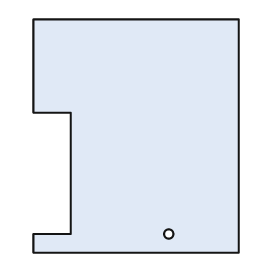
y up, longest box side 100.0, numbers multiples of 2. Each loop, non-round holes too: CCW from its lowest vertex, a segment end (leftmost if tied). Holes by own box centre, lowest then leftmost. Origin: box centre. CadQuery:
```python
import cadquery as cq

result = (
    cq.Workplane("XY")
    .moveTo(-44.0, -50.0)
    .lineTo(44.0, -50.0)
    .lineTo(44.0, 50.0)
    .lineTo(-44.0, 50.0)
    .lineTo(-44.0, 10.0)
    .lineTo(-28.0, 10.0)
    .lineTo(-28.0, -42.0)
    .lineTo(-44.0, -42.0)
    .close()
    .moveTo(14.0, -42.0)
    .circle(2.0)
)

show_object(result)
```